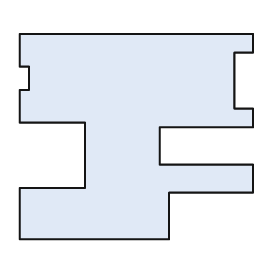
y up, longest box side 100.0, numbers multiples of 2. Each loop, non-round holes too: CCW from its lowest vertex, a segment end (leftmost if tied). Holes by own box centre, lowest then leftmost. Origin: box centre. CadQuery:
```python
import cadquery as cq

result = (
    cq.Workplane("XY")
    .moveTo(-50.0, -44.0)
    .lineTo(14.0, -44.0)
    .lineTo(14.0, -24.0)
    .lineTo(50.0, -24.0)
    .lineTo(50.0, -12.0)
    .lineTo(10.0, -12.0)
    .lineTo(10.0, 4.0)
    .lineTo(50.0, 4.0)
    .lineTo(50.0, 12.0)
    .lineTo(42.0, 12.0)
    .lineTo(42.0, 36.0)
    .lineTo(50.0, 36.0)
    .lineTo(50.0, 44.0)
    .lineTo(-50.0, 44.0)
    .lineTo(-50.0, 30.0)
    .lineTo(-46.0, 30.0)
    .lineTo(-46.0, 20.0)
    .lineTo(-50.0, 20.0)
    .lineTo(-50.0, 6.0)
    .lineTo(-22.0, 6.0)
    .lineTo(-22.0, -22.0)
    .lineTo(-50.0, -22.0)
    .close()
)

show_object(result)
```